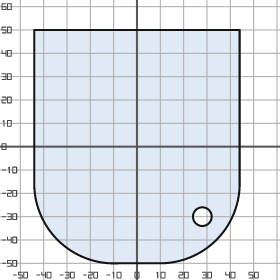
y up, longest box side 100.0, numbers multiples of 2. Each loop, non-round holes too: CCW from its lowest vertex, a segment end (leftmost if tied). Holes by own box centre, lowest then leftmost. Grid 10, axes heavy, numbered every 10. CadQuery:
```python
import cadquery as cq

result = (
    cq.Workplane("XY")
    .moveTo(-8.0, -50.0)
    .lineTo(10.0, -50.0)
    .threePointArc((34.0, -40.0), (44.0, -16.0))
    .lineTo(44.0, 50.0)
    .lineTo(-44.0, 50.0)
    .lineTo(-44.0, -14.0)
    .threePointArc((-34.0, -40.0), (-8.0, -50.0))
    .close()
    .moveTo(28.0, -30.0)
    .circle(4.0)
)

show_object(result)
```